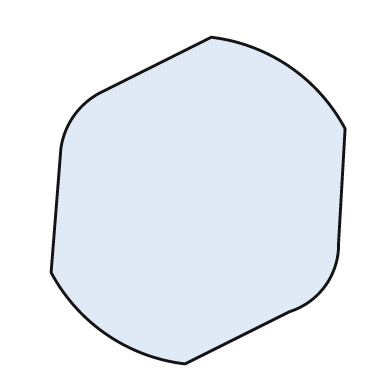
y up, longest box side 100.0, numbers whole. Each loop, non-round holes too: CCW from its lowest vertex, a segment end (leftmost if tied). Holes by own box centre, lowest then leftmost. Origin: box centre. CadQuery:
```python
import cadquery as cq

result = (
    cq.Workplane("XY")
    .moveTo(-4.0, -50.0)
    .lineTo(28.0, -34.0)
    .threePointArc((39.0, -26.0), (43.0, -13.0))
    .lineTo(45.0, 22.0)
    .threePointArc((28.0, 41.0), (4.0, 50.0))
    .lineTo(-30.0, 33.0)
    .threePointArc((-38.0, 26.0), (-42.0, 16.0))
    .lineTo(-45.0, -22.0)
    .threePointArc((-28.0, -41.0), (-4.0, -50.0))
    .close()
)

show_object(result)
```